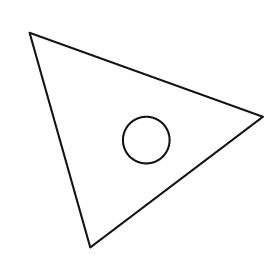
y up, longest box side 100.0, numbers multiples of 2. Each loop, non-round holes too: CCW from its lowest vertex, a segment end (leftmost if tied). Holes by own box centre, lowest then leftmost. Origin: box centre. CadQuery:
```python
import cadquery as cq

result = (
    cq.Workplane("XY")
    .moveTo(-24.0, -46.0)
    .lineTo(50.0, 10.0)
    .lineTo(-50.0, 46.0)
    .close()
    .moveTo(0.0, 0.0)
    .circle(10.0)
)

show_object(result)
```